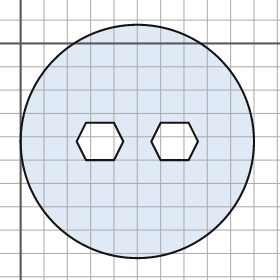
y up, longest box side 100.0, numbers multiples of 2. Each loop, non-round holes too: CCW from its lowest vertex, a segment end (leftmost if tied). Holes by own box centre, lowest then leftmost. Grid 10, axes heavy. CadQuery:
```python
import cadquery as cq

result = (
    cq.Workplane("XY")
    .moveTo(50.0, -42.0)
    .circle(50.0)
    .moveTo(28.0, -50.0)
    .lineTo(40.0, -50.0)
    .lineTo(44.0, -42.0)
    .lineTo(40.0, -34.0)
    .lineTo(28.0, -34.0)
    .lineTo(24.0, -42.0)
    .close()
    .moveTo(60.0, -50.0)
    .lineTo(72.0, -50.0)
    .lineTo(76.0, -42.0)
    .lineTo(72.0, -34.0)
    .lineTo(60.0, -34.0)
    .lineTo(56.0, -42.0)
    .close()
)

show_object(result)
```